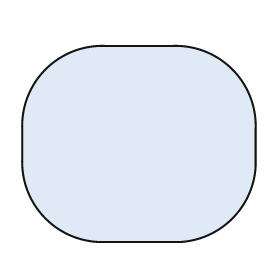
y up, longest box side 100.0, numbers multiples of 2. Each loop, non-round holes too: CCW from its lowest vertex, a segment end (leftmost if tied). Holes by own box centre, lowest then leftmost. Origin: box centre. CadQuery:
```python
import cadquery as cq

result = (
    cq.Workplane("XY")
    .moveTo(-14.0, -42.0)
    .lineTo(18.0, -42.0)
    .threePointArc((40.0, -32.0), (50.0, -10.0))
    .lineTo(50.0, 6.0)
    .threePointArc((40.0, 32.0), (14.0, 42.0))
    .lineTo(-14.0, 42.0)
    .threePointArc((-40.0, 32.0), (-50.0, 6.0))
    .lineTo(-50.0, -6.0)
    .threePointArc((-40.0, -32.0), (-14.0, -42.0))
    .close()
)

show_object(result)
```